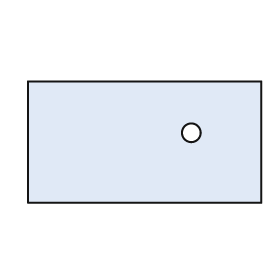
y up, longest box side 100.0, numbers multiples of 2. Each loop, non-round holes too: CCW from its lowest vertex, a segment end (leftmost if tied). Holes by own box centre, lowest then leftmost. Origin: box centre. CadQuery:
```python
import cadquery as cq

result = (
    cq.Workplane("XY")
    .moveTo(-50.0, -26.0)
    .lineTo(50.0, -26.0)
    .lineTo(50.0, 26.0)
    .lineTo(-50.0, 26.0)
    .close()
    .moveTo(20.0, 4.0)
    .circle(4.0)
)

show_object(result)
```